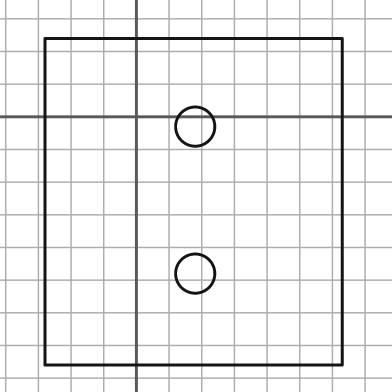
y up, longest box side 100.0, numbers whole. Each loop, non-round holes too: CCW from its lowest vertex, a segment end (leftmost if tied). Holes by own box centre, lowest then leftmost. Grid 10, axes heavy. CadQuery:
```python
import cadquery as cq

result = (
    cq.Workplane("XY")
    .moveTo(-28.0, -76.0)
    .lineTo(63.0, -76.0)
    .lineTo(63.0, 24.0)
    .lineTo(-28.0, 24.0)
    .close()
    .moveTo(18.0, -48.0)
    .circle(6.0)
    .moveTo(18.0, -3.0)
    .circle(6.0)
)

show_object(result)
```